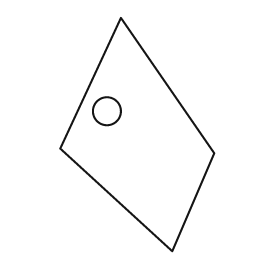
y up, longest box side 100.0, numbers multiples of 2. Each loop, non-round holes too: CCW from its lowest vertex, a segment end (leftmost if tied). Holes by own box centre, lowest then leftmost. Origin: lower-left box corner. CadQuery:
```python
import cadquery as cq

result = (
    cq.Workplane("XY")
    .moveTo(48.0, 0.0)
    .lineTo(66.0, 42.0)
    .lineTo(26.0, 100.0)
    .lineTo(0.0, 44.0)
    .close()
    .moveTo(20.0, 60.0)
    .circle(6.0)
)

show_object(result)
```